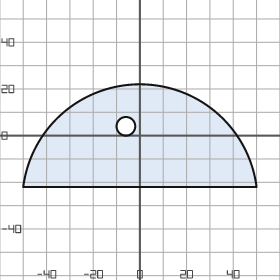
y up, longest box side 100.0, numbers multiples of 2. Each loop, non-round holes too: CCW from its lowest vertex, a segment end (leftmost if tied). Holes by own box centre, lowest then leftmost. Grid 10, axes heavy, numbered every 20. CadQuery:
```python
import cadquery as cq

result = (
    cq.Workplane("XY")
    .moveTo(-50.0, -22.0)
    .lineTo(50.0, -22.0)
    .threePointArc((0.0, 22.0), (-50.0, -22.0))
    .close()
    .moveTo(-6.0, 4.0)
    .circle(4.0)
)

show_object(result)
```